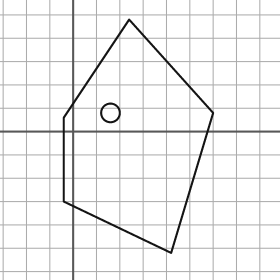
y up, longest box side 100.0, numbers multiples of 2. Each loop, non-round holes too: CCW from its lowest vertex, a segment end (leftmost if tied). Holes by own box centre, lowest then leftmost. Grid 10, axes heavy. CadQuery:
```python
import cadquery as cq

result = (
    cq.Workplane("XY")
    .moveTo(42.0, -52.0)
    .lineTo(60.0, 8.0)
    .lineTo(24.0, 48.0)
    .lineTo(-4.0, 6.0)
    .lineTo(-4.0, -30.0)
    .close()
    .moveTo(16.0, 8.0)
    .circle(4.0)
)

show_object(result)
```